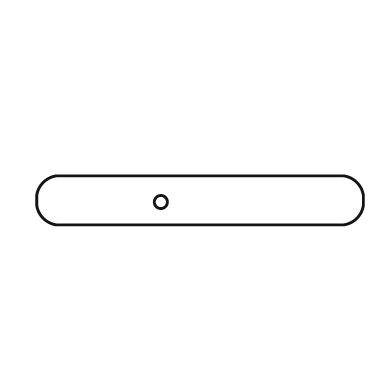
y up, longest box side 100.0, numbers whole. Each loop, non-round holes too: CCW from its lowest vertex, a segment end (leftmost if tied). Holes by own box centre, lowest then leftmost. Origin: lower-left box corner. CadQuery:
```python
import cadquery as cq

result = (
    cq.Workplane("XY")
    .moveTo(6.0, 0.0)
    .lineTo(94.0, 0.0)
    .threePointArc((98.0, 2.0), (100.0, 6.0))
    .lineTo(100.0, 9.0)
    .threePointArc((98.0, 13.0), (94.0, 15.0))
    .lineTo(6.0, 15.0)
    .threePointArc((2.0, 13.0), (0.0, 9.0))
    .lineTo(0.0, 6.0)
    .threePointArc((2.0, 2.0), (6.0, 0.0))
    .close()
    .moveTo(38.0, 7.0)
    .circle(2.0)
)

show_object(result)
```